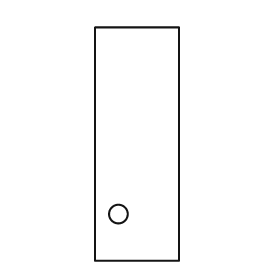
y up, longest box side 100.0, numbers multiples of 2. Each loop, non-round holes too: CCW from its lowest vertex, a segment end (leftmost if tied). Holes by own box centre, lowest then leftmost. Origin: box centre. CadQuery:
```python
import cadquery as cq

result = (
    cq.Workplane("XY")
    .moveTo(-18.0, -50.0)
    .lineTo(18.0, -50.0)
    .lineTo(18.0, 50.0)
    .lineTo(-18.0, 50.0)
    .close()
    .moveTo(-8.0, -30.0)
    .circle(4.0)
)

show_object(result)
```